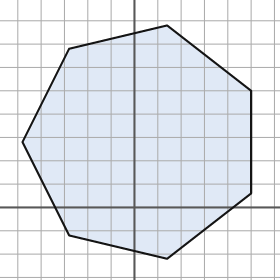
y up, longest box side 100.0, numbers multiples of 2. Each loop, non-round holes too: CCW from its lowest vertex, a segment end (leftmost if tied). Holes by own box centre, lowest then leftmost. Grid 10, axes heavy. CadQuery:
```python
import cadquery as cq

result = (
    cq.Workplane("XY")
    .moveTo(14.0, -22.0)
    .lineTo(50.0, 6.0)
    .lineTo(50.0, 50.0)
    .lineTo(14.0, 78.0)
    .lineTo(-28.0, 68.0)
    .lineTo(-48.0, 28.0)
    .lineTo(-28.0, -12.0)
    .close()
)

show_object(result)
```